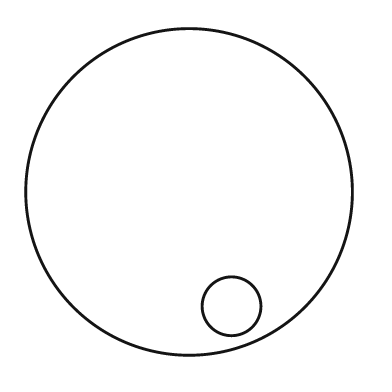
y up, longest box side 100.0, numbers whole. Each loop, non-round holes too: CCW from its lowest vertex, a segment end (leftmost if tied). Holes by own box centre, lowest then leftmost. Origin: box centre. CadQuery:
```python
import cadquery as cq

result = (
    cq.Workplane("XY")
    .moveTo(0.0, 0.0)
    .circle(50.0)
    .moveTo(13.0, -35.0)
    .circle(9.0)
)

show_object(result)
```